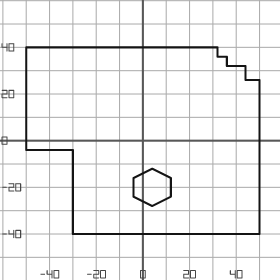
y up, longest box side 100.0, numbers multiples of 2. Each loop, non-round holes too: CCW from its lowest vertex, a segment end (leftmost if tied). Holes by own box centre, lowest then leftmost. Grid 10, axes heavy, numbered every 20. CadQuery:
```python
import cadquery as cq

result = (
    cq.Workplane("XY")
    .moveTo(-30.0, -40.0)
    .lineTo(50.0, -40.0)
    .lineTo(50.0, 26.0)
    .lineTo(44.0, 26.0)
    .lineTo(44.0, 32.0)
    .lineTo(36.0, 32.0)
    .lineTo(36.0, 36.0)
    .lineTo(32.0, 36.0)
    .lineTo(32.0, 40.0)
    .lineTo(-50.0, 40.0)
    .lineTo(-50.0, -4.0)
    .lineTo(-30.0, -4.0)
    .close()
    .moveTo(4.0, -28.0)
    .lineTo(12.0, -24.0)
    .lineTo(12.0, -16.0)
    .lineTo(4.0, -12.0)
    .lineTo(-4.0, -16.0)
    .lineTo(-4.0, -24.0)
    .close()
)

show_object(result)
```